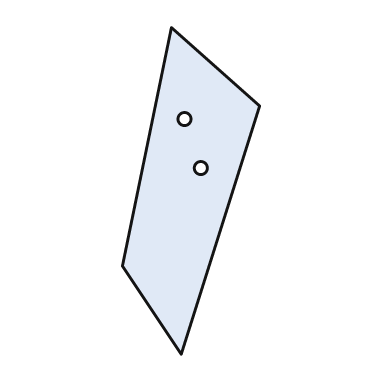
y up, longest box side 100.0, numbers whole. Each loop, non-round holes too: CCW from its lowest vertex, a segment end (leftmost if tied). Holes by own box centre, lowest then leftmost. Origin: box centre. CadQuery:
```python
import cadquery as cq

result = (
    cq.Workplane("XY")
    .moveTo(-3.0, -50.0)
    .lineTo(21.0, 26.0)
    .lineTo(-6.0, 50.0)
    .lineTo(-21.0, -23.0)
    .close()
    .moveTo(3.0, 7.0)
    .circle(2.0)
    .moveTo(-2.0, 22.0)
    .circle(2.0)
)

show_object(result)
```